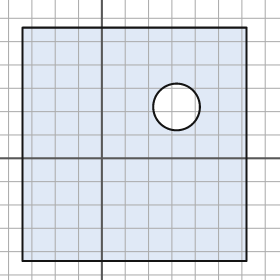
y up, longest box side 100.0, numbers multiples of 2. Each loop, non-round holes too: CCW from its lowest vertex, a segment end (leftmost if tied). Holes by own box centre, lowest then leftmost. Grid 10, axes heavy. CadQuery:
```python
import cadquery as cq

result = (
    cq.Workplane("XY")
    .moveTo(-34.0, -44.0)
    .lineTo(62.0, -44.0)
    .lineTo(62.0, 56.0)
    .lineTo(-34.0, 56.0)
    .close()
    .moveTo(32.0, 22.0)
    .circle(10.0)
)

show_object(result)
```